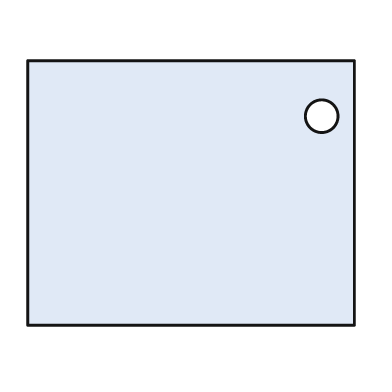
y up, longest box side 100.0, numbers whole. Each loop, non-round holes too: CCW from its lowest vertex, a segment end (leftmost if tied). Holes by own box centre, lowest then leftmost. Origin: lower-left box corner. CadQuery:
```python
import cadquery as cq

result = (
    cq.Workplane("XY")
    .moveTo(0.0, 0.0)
    .lineTo(100.0, 0.0)
    .lineTo(100.0, 81.0)
    .lineTo(0.0, 81.0)
    .close()
    .moveTo(90.0, 64.0)
    .circle(5.0)
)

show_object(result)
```